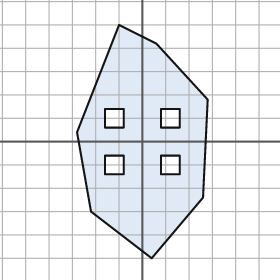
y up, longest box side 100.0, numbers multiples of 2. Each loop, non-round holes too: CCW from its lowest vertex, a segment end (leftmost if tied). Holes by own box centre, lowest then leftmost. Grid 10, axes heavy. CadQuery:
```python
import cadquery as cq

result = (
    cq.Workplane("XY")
    .moveTo(4.0, -50.0)
    .lineTo(26.0, -24.0)
    .lineTo(28.0, 18.0)
    .lineTo(6.0, 42.0)
    .lineTo(-10.0, 50.0)
    .lineTo(-28.0, 4.0)
    .lineTo(-22.0, -30.0)
    .close()
    .moveTo(-16.0, -14.0)
    .lineTo(-8.0, -14.0)
    .lineTo(-8.0, -6.0)
    .lineTo(-16.0, -6.0)
    .close()
    .moveTo(8.0, -14.0)
    .lineTo(16.0, -14.0)
    .lineTo(16.0, -6.0)
    .lineTo(8.0, -6.0)
    .close()
    .moveTo(-16.0, 6.0)
    .lineTo(-8.0, 6.0)
    .lineTo(-8.0, 14.0)
    .lineTo(-16.0, 14.0)
    .close()
    .moveTo(8.0, 6.0)
    .lineTo(16.0, 6.0)
    .lineTo(16.0, 14.0)
    .lineTo(8.0, 14.0)
    .close()
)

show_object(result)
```